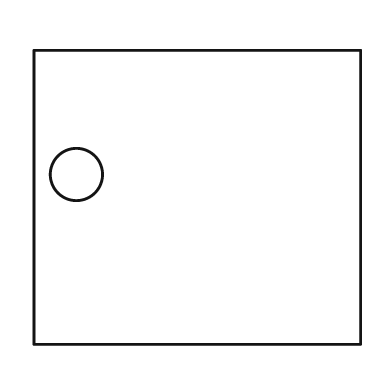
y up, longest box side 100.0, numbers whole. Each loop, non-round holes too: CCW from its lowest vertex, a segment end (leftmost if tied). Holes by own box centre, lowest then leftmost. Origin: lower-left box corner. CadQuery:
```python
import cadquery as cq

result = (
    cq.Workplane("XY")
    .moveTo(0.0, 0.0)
    .lineTo(100.0, 0.0)
    .lineTo(100.0, 90.0)
    .lineTo(0.0, 90.0)
    .close()
    .moveTo(13.0, 52.0)
    .circle(8.0)
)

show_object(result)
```